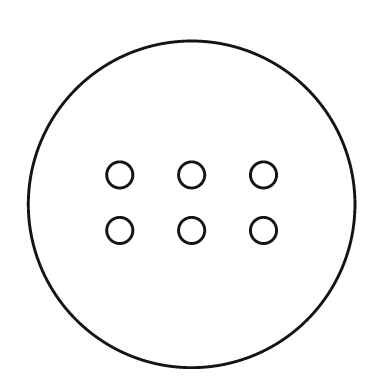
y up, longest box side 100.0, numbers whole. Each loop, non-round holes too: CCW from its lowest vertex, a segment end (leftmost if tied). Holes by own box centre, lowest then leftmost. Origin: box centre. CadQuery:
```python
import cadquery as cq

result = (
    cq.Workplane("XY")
    .moveTo(0.0, 0.0)
    .circle(50.0)
    .moveTo(-22.0, -8.0)
    .circle(4.0)
    .moveTo(0.0, -8.0)
    .circle(4.0)
    .moveTo(22.0, -8.0)
    .circle(4.0)
    .moveTo(-22.0, 9.0)
    .circle(4.0)
    .moveTo(0.0, 9.0)
    .circle(4.0)
    .moveTo(22.0, 9.0)
    .circle(4.0)
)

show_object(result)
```